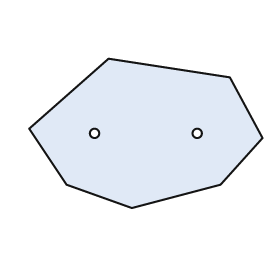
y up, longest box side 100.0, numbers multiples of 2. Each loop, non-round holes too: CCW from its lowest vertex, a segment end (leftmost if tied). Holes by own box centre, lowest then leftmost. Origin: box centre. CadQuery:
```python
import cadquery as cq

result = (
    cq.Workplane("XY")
    .moveTo(-6.0, -32.0)
    .lineTo(32.0, -22.0)
    .lineTo(50.0, -2.0)
    .lineTo(36.0, 24.0)
    .lineTo(-16.0, 32.0)
    .lineTo(-50.0, 2.0)
    .lineTo(-34.0, -22.0)
    .close()
    .moveTo(-22.0, 0.0)
    .circle(2.0)
    .moveTo(22.0, 0.0)
    .circle(2.0)
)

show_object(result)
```